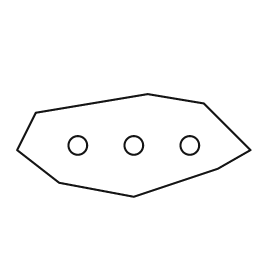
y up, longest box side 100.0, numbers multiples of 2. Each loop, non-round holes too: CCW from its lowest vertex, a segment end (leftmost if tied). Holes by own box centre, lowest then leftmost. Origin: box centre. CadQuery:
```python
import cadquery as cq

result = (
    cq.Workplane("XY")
    .moveTo(0.0, -22.0)
    .lineTo(36.0, -10.0)
    .lineTo(50.0, -2.0)
    .lineTo(30.0, 18.0)
    .lineTo(6.0, 22.0)
    .lineTo(-42.0, 14.0)
    .lineTo(-50.0, -2.0)
    .lineTo(-32.0, -16.0)
    .close()
    .moveTo(-24.0, 0.0)
    .circle(4.0)
    .moveTo(0.0, 0.0)
    .circle(4.0)
    .moveTo(24.0, 0.0)
    .circle(4.0)
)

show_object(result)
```